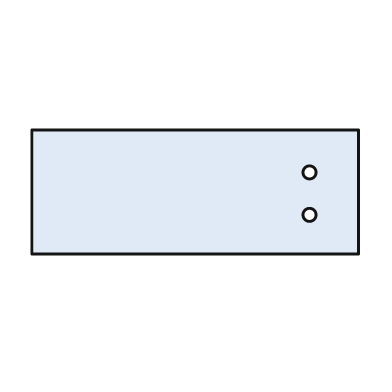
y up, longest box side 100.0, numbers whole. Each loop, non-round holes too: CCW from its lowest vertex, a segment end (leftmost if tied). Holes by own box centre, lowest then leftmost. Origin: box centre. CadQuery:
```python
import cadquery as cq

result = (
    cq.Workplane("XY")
    .moveTo(-50.0, -19.0)
    .lineTo(50.0, -19.0)
    .lineTo(50.0, 19.0)
    .lineTo(-50.0, 19.0)
    .close()
    .moveTo(35.0, -7.0)
    .circle(2.0)
    .moveTo(35.0, 6.0)
    .circle(2.0)
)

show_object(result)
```